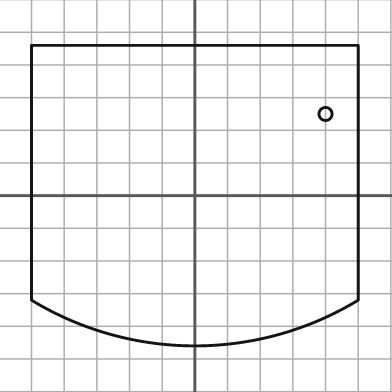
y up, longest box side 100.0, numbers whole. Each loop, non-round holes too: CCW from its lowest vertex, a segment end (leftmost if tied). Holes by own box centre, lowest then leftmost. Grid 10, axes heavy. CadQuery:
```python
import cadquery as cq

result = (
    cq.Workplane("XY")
    .moveTo(-50.0, -32.0)
    .threePointArc((0.0, -46.0), (50.0, -32.0))
    .lineTo(50.0, 46.0)
    .lineTo(-50.0, 46.0)
    .close()
    .moveTo(40.0, 25.0)
    .circle(2.0)
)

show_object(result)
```